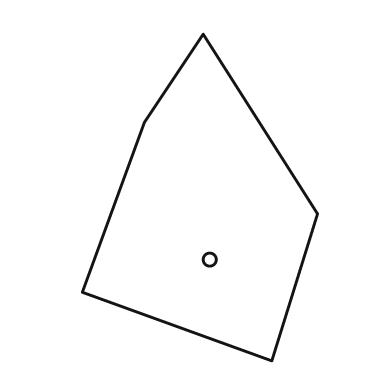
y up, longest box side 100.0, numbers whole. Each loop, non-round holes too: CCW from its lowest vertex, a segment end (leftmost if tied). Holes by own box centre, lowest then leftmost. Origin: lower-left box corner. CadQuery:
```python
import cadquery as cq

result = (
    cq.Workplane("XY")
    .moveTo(58.0, 0.0)
    .lineTo(72.0, 45.0)
    .lineTo(37.0, 100.0)
    .lineTo(19.0, 73.0)
    .lineTo(0.0, 21.0)
    .close()
    .moveTo(39.0, 31.0)
    .circle(2.0)
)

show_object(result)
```